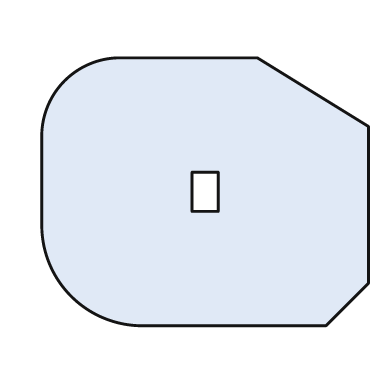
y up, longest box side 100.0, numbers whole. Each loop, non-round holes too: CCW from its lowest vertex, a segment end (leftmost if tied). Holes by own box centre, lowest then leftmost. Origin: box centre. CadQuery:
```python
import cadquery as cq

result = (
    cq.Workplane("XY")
    .moveTo(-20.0, -41.0)
    .lineTo(37.0, -41.0)
    .lineTo(50.0, -28.0)
    .lineTo(50.0, 20.0)
    .lineTo(16.0, 41.0)
    .lineTo(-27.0, 41.0)
    .threePointArc((-43.0, 34.0), (-50.0, 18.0))
    .lineTo(-50.0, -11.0)
    .threePointArc((-41.0, -32.0), (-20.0, -41.0))
    .close()
    .moveTo(-4.0, -6.0)
    .lineTo(4.0, -6.0)
    .lineTo(4.0, 6.0)
    .lineTo(-4.0, 6.0)
    .close()
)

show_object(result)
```